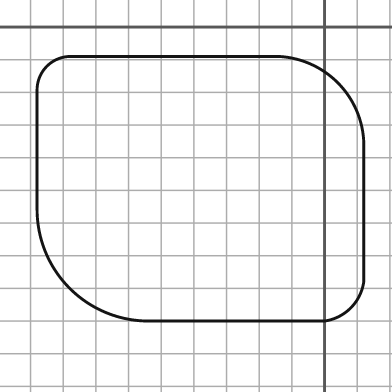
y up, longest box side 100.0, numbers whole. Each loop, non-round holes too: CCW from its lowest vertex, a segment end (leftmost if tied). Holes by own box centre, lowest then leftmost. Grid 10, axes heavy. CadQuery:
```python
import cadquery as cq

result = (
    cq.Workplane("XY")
    .moveTo(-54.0, -90.0)
    .lineTo(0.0, -90.0)
    .threePointArc((8.0, -86.0), (12.0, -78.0))
    .lineTo(12.0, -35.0)
    .threePointArc((4.0, -17.0), (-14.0, -9.0))
    .lineTo(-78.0, -9.0)
    .threePointArc((-85.0, -12.0), (-88.0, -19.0))
    .lineTo(-88.0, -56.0)
    .threePointArc((-78.0, -80.0), (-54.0, -90.0))
    .close()
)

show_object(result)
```